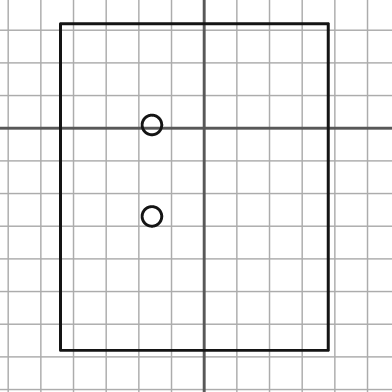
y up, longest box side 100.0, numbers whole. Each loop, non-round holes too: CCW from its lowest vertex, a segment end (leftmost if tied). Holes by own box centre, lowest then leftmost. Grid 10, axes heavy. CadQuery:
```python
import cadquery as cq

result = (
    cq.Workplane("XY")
    .moveTo(-44.0, -68.0)
    .lineTo(38.0, -68.0)
    .lineTo(38.0, 32.0)
    .lineTo(-44.0, 32.0)
    .close()
    .moveTo(-16.0, -27.0)
    .circle(3.0)
    .moveTo(-16.0, 1.0)
    .circle(3.0)
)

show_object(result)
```